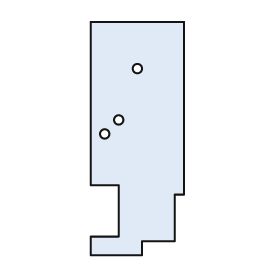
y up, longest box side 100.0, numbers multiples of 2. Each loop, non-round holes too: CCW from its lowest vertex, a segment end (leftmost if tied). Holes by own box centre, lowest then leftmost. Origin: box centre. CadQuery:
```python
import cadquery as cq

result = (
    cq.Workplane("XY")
    .moveTo(-20.0, -50.0)
    .lineTo(2.0, -50.0)
    .lineTo(2.0, -44.0)
    .lineTo(16.0, -44.0)
    .lineTo(16.0, -24.0)
    .lineTo(20.0, -24.0)
    .lineTo(20.0, 50.0)
    .lineTo(-20.0, 50.0)
    .lineTo(-20.0, -20.0)
    .lineTo(-8.0, -20.0)
    .lineTo(-8.0, -42.0)
    .lineTo(-20.0, -42.0)
    .close()
    .moveTo(-14.0, 2.0)
    .circle(2.0)
    .moveTo(-8.0, 8.0)
    .circle(2.0)
    .moveTo(0.0, 30.0)
    .circle(2.0)
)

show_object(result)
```